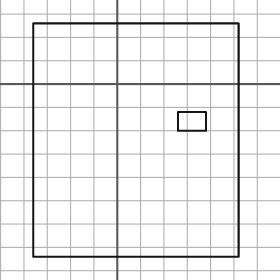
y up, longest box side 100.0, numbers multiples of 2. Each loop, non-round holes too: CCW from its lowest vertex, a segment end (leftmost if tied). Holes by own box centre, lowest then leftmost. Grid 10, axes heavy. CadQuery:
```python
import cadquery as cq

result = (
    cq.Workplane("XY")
    .moveTo(-36.0, -74.0)
    .lineTo(52.0, -74.0)
    .lineTo(52.0, 26.0)
    .lineTo(-36.0, 26.0)
    .close()
    .moveTo(26.0, -20.0)
    .lineTo(38.0, -20.0)
    .lineTo(38.0, -12.0)
    .lineTo(26.0, -12.0)
    .close()
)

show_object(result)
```